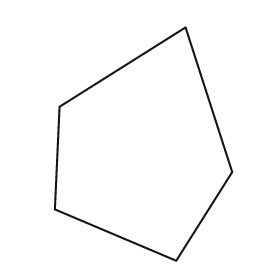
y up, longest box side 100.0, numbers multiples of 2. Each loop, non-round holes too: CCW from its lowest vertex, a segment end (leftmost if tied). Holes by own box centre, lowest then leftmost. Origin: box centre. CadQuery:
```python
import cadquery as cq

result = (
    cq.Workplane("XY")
    .moveTo(14.0, -50.0)
    .lineTo(38.0, -12.0)
    .lineTo(18.0, 50.0)
    .lineTo(-36.0, 16.0)
    .lineTo(-38.0, -28.0)
    .close()
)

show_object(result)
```